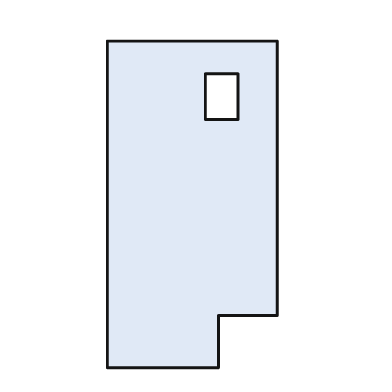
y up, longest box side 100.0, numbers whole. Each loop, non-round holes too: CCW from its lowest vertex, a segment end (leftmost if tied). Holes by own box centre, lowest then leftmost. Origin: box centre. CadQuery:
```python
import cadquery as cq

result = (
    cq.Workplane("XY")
    .moveTo(-26.0, -50.0)
    .lineTo(8.0, -50.0)
    .lineTo(8.0, -34.0)
    .lineTo(26.0, -34.0)
    .lineTo(26.0, 50.0)
    .lineTo(-26.0, 50.0)
    .close()
    .moveTo(4.0, 26.0)
    .lineTo(14.0, 26.0)
    .lineTo(14.0, 40.0)
    .lineTo(4.0, 40.0)
    .close()
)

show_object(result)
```